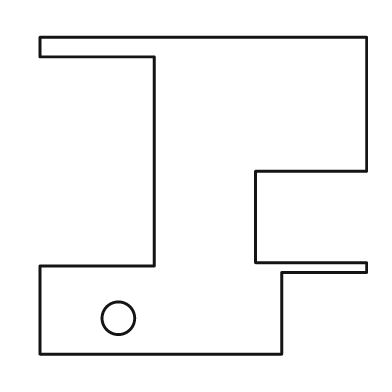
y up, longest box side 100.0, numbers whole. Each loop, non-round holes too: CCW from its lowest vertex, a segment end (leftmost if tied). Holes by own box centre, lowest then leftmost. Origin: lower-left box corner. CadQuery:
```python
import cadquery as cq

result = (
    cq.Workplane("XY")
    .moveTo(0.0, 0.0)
    .lineTo(74.0, 0.0)
    .lineTo(74.0, 25.0)
    .lineTo(100.0, 25.0)
    .lineTo(100.0, 28.0)
    .lineTo(66.0, 28.0)
    .lineTo(66.0, 56.0)
    .lineTo(100.0, 56.0)
    .lineTo(100.0, 97.0)
    .lineTo(0.0, 97.0)
    .lineTo(0.0, 91.0)
    .lineTo(35.0, 91.0)
    .lineTo(35.0, 27.0)
    .lineTo(0.0, 27.0)
    .close()
    .moveTo(24.0, 11.0)
    .circle(5.0)
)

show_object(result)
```